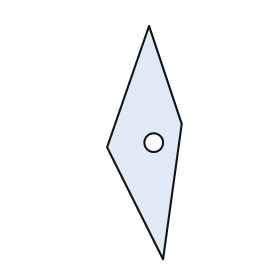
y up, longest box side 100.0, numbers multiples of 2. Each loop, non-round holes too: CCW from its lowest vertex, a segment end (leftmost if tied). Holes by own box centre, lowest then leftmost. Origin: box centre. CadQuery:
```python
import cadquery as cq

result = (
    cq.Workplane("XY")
    .moveTo(8.0, -50.0)
    .lineTo(16.0, 8.0)
    .lineTo(2.0, 50.0)
    .lineTo(-16.0, -2.0)
    .close()
    .moveTo(4.0, 0.0)
    .circle(4.0)
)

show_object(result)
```